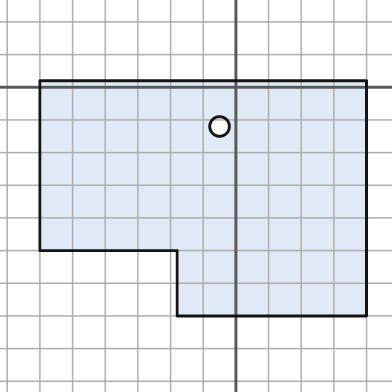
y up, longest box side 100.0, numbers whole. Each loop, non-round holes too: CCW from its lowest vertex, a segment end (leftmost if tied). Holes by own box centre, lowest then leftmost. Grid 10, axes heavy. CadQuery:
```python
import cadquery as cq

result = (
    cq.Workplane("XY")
    .moveTo(-18.0, -70.0)
    .lineTo(40.0, -70.0)
    .lineTo(40.0, 2.0)
    .lineTo(-60.0, 2.0)
    .lineTo(-60.0, -50.0)
    .lineTo(-18.0, -50.0)
    .close()
    .moveTo(-5.0, -12.0)
    .circle(3.0)
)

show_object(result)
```